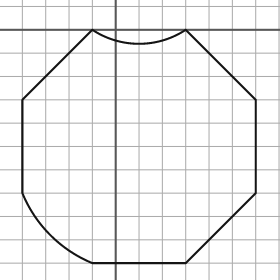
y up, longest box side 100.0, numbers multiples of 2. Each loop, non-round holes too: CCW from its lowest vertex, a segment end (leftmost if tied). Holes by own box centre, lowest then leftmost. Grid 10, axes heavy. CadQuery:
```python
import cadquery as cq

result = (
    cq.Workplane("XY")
    .moveTo(-10.0, -100.0)
    .lineTo(30.0, -100.0)
    .lineTo(60.0, -70.0)
    .lineTo(60.0, -30.0)
    .lineTo(30.0, 0.0)
    .threePointArc((10.0, -6.0), (-10.0, 0.0))
    .lineTo(-40.0, -30.0)
    .lineTo(-40.0, -70.0)
    .threePointArc((-28.0, -88.0), (-10.0, -100.0))
    .close()
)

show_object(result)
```